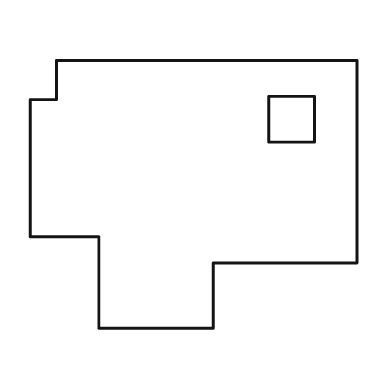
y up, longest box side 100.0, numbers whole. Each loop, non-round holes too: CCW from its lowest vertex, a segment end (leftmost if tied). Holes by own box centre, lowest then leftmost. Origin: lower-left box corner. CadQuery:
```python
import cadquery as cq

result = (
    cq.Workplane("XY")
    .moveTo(21.0, 0.0)
    .lineTo(56.0, 0.0)
    .lineTo(56.0, 20.0)
    .lineTo(100.0, 20.0)
    .lineTo(100.0, 82.0)
    .lineTo(8.0, 82.0)
    .lineTo(8.0, 70.0)
    .lineTo(0.0, 70.0)
    .lineTo(0.0, 28.0)
    .lineTo(21.0, 28.0)
    .close()
    .moveTo(73.0, 57.0)
    .lineTo(87.0, 57.0)
    .lineTo(87.0, 71.0)
    .lineTo(73.0, 71.0)
    .close()
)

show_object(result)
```